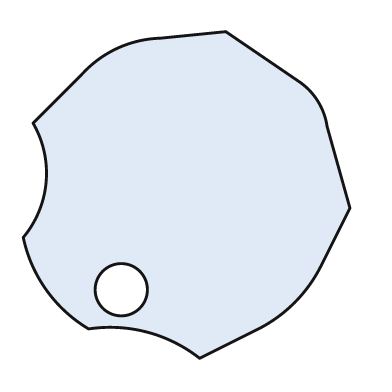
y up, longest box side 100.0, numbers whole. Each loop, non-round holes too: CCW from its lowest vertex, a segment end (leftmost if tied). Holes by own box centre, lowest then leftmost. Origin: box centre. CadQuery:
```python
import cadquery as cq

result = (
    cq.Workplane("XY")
    .moveTo(4.0, -50.0)
    .lineTo(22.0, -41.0)
    .threePointArc((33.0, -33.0), (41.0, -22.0))
    .lineTo(50.0, -4.0)
    .lineTo(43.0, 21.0)
    .threePointArc((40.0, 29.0), (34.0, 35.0))
    .lineTo(12.0, 50.0)
    .lineTo(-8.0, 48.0)
    .threePointArc((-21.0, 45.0), (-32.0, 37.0))
    .lineTo(-47.0, 22.0)
    .threePointArc((-43.0, 4.0), (-50.0, -13.0))
    .threePointArc((-43.0, -29.0), (-30.0, -41.0))
    .threePointArc((-12.0, -42.0), (4.0, -50.0))
    .close()
    .moveTo(-20.0, -29.0)
    .circle(8.0)
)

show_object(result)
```